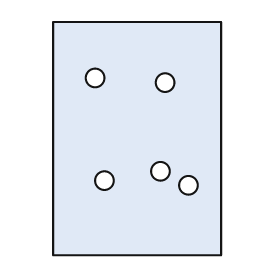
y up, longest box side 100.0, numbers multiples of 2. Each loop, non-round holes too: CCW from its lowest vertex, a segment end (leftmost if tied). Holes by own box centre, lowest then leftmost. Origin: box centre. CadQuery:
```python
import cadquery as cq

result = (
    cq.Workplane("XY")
    .moveTo(-36.0, -50.0)
    .lineTo(36.0, -50.0)
    .lineTo(36.0, 50.0)
    .lineTo(-36.0, 50.0)
    .close()
    .moveTo(22.0, -20.0)
    .circle(4.0)
    .moveTo(-14.0, -18.0)
    .circle(4.0)
    .moveTo(10.0, -14.0)
    .circle(4.0)
    .moveTo(12.0, 24.0)
    .circle(4.0)
    .moveTo(-18.0, 26.0)
    .circle(4.0)
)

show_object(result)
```